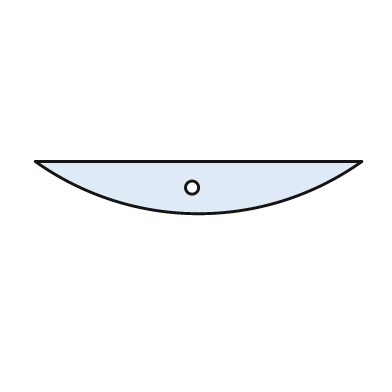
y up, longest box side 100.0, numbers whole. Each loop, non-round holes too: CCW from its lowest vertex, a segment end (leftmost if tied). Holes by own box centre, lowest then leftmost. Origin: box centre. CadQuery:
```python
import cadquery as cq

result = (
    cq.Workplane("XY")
    .moveTo(-50.0, 8.0)
    .threePointArc((0.0, -8.0), (50.0, 8.0))
    .close()
    .moveTo(-2.0, 0.0)
    .circle(2.0)
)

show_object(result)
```